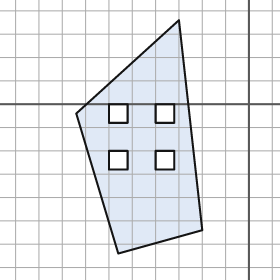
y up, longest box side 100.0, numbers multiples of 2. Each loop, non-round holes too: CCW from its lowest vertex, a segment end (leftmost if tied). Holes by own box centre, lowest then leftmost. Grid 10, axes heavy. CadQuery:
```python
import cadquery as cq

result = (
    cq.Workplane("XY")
    .moveTo(-56.0, -64.0)
    .lineTo(-20.0, -54.0)
    .lineTo(-30.0, 36.0)
    .lineTo(-74.0, -4.0)
    .close()
    .moveTo(-60.0, -28.0)
    .lineTo(-52.0, -28.0)
    .lineTo(-52.0, -20.0)
    .lineTo(-60.0, -20.0)
    .close()
    .moveTo(-40.0, -28.0)
    .lineTo(-32.0, -28.0)
    .lineTo(-32.0, -20.0)
    .lineTo(-40.0, -20.0)
    .close()
    .moveTo(-60.0, -8.0)
    .lineTo(-52.0, -8.0)
    .lineTo(-52.0, 0.0)
    .lineTo(-60.0, 0.0)
    .close()
    .moveTo(-40.0, -8.0)
    .lineTo(-32.0, -8.0)
    .lineTo(-32.0, 0.0)
    .lineTo(-40.0, 0.0)
    .close()
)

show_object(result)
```